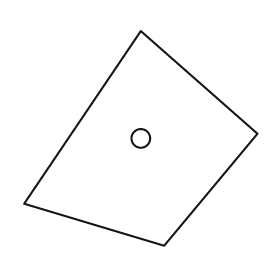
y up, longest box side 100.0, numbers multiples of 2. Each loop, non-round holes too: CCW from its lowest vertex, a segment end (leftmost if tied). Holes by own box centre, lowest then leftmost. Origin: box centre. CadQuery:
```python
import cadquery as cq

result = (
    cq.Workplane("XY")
    .moveTo(10.0, -46.0)
    .lineTo(50.0, 2.0)
    .lineTo(0.0, 46.0)
    .lineTo(-50.0, -28.0)
    .close()
    .moveTo(0.0, 0.0)
    .circle(4.0)
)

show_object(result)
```